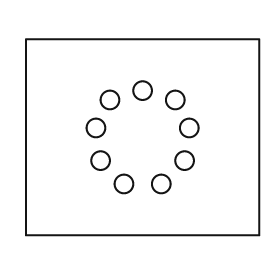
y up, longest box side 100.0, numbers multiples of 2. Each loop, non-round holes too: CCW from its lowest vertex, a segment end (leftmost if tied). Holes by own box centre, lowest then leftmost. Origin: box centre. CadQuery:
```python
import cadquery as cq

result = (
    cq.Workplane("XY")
    .moveTo(-50.0, -42.0)
    .lineTo(50.0, -42.0)
    .lineTo(50.0, 42.0)
    .lineTo(-50.0, 42.0)
    .close()
    .moveTo(-8.0, -20.0)
    .circle(4.0)
    .moveTo(8.0, -20.0)
    .circle(4.0)
    .moveTo(-18.0, -10.0)
    .circle(4.0)
    .moveTo(18.0, -10.0)
    .circle(4.0)
    .moveTo(-20.0, 4.0)
    .circle(4.0)
    .moveTo(20.0, 4.0)
    .circle(4.0)
    .moveTo(-14.0, 16.0)
    .circle(4.0)
    .moveTo(14.0, 16.0)
    .circle(4.0)
    .moveTo(0.0, 20.0)
    .circle(4.0)
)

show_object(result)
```